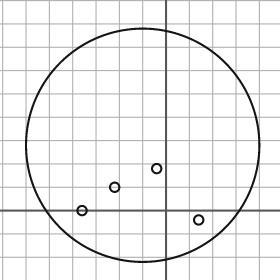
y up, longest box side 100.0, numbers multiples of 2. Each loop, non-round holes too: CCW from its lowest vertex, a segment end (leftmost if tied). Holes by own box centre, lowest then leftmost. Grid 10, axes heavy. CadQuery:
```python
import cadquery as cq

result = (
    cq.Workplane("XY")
    .moveTo(-10.0, 28.0)
    .circle(50.0)
    .moveTo(14.0, -4.0)
    .circle(2.0)
    .moveTo(-36.0, 0.0)
    .circle(2.0)
    .moveTo(-22.0, 10.0)
    .circle(2.0)
    .moveTo(-4.0, 18.0)
    .circle(2.0)
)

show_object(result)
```